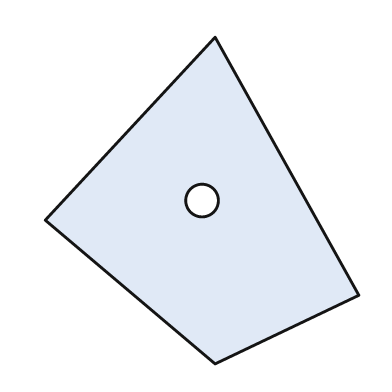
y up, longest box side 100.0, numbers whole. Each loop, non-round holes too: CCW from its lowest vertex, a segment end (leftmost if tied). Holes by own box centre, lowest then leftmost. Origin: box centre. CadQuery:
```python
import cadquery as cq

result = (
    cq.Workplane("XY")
    .moveTo(4.0, -50.0)
    .lineTo(48.0, -29.0)
    .lineTo(4.0, 50.0)
    .lineTo(-48.0, -6.0)
    .close()
    .moveTo(0.0, 0.0)
    .circle(5.0)
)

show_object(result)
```